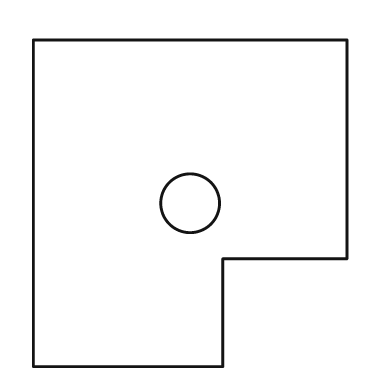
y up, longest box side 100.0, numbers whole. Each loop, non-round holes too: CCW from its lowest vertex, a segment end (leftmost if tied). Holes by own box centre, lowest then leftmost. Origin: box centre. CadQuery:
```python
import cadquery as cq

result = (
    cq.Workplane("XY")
    .moveTo(-48.0, -50.0)
    .lineTo(10.0, -50.0)
    .lineTo(10.0, -17.0)
    .lineTo(48.0, -17.0)
    .lineTo(48.0, 50.0)
    .lineTo(-48.0, 50.0)
    .close()
    .moveTo(0.0, 0.0)
    .circle(9.0)
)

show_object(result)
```